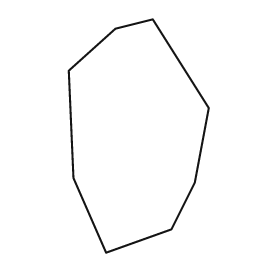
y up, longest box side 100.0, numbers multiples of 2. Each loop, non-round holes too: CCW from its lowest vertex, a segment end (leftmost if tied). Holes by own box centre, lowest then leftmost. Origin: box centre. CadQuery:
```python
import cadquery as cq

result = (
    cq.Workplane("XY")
    .moveTo(-14.0, -50.0)
    .lineTo(14.0, -40.0)
    .lineTo(24.0, -20.0)
    .lineTo(30.0, 12.0)
    .lineTo(6.0, 50.0)
    .lineTo(-10.0, 46.0)
    .lineTo(-30.0, 28.0)
    .lineTo(-28.0, -18.0)
    .close()
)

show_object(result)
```